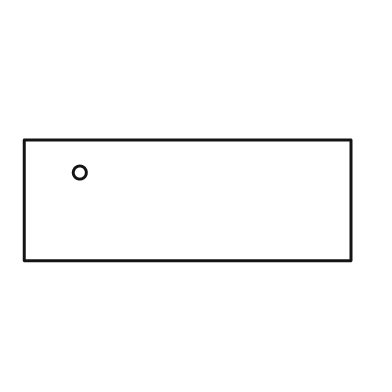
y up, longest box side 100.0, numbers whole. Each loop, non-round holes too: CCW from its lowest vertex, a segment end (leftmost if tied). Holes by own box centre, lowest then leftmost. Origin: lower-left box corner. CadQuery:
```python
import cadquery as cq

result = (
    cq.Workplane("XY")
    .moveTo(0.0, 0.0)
    .lineTo(100.0, 0.0)
    .lineTo(100.0, 37.0)
    .lineTo(0.0, 37.0)
    .close()
    .moveTo(17.0, 27.0)
    .circle(2.0)
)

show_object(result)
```